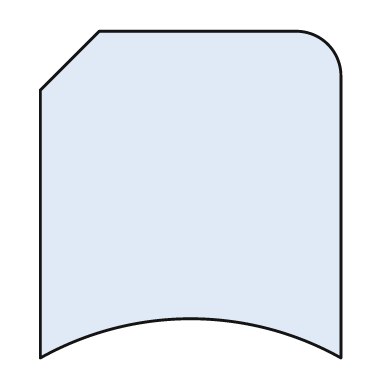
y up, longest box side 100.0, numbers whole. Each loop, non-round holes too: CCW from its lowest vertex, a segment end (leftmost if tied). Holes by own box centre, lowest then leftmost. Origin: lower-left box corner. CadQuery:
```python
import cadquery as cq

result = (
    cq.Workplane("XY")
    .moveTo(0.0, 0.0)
    .threePointArc((46.0, 12.0), (92.0, 0.0))
    .lineTo(92.0, 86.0)
    .threePointArc((88.0, 96.0), (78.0, 100.0))
    .lineTo(18.0, 100.0)
    .lineTo(0.0, 82.0)
    .close()
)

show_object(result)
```